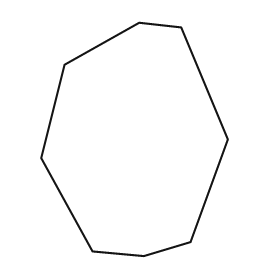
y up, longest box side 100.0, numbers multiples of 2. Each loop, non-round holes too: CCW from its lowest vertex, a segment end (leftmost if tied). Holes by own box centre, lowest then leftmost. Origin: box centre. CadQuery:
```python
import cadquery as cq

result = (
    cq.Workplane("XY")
    .moveTo(4.0, -50.0)
    .lineTo(24.0, -44.0)
    .lineTo(40.0, 0.0)
    .lineTo(20.0, 48.0)
    .lineTo(2.0, 50.0)
    .lineTo(-30.0, 32.0)
    .lineTo(-40.0, -8.0)
    .lineTo(-18.0, -48.0)
    .close()
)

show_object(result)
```